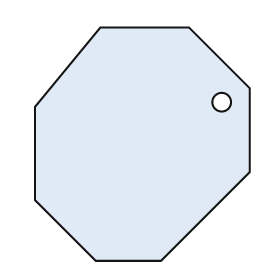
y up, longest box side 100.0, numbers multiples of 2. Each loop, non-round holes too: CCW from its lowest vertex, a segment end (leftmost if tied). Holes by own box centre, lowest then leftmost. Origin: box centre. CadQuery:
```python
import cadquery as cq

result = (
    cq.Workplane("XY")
    .moveTo(-20.0, -50.0)
    .lineTo(8.0, -50.0)
    .lineTo(46.0, -12.0)
    .lineTo(46.0, 24.0)
    .lineTo(20.0, 50.0)
    .lineTo(-18.0, 50.0)
    .lineTo(-46.0, 16.0)
    .lineTo(-46.0, -24.0)
    .close()
    .moveTo(34.0, 18.0)
    .circle(4.0)
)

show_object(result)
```